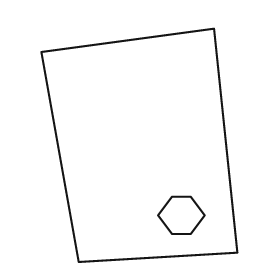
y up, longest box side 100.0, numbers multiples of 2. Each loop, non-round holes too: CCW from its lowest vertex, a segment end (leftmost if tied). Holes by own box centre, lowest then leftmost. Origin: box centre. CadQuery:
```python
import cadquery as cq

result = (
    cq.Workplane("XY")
    .moveTo(-26.0, -50.0)
    .lineTo(42.0, -46.0)
    .lineTo(32.0, 50.0)
    .lineTo(-42.0, 40.0)
    .close()
    .moveTo(14.0, -38.0)
    .lineTo(22.0, -38.0)
    .lineTo(28.0, -30.0)
    .lineTo(22.0, -22.0)
    .lineTo(14.0, -22.0)
    .lineTo(8.0, -30.0)
    .close()
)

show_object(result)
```